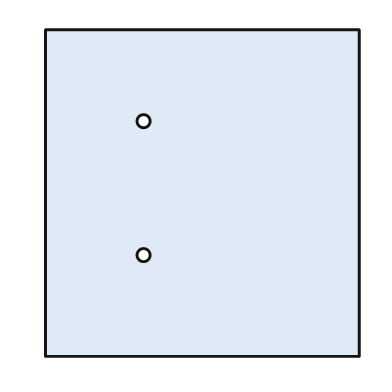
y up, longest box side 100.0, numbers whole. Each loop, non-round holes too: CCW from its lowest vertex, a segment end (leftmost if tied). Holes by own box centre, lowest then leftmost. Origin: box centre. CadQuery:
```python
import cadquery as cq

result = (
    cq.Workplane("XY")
    .moveTo(-48.0, -50.0)
    .lineTo(48.0, -50.0)
    .lineTo(48.0, 50.0)
    .lineTo(-48.0, 50.0)
    .close()
    .moveTo(-18.0, -19.0)
    .circle(2.0)
    .moveTo(-18.0, 22.0)
    .circle(2.0)
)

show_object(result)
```